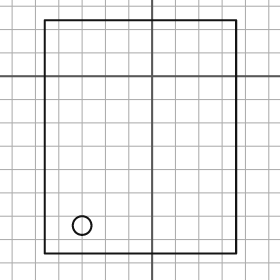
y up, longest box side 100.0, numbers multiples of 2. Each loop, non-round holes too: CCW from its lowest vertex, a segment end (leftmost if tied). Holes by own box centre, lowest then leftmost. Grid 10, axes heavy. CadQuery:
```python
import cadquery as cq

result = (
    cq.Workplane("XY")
    .moveTo(-46.0, -76.0)
    .lineTo(36.0, -76.0)
    .lineTo(36.0, 24.0)
    .lineTo(-46.0, 24.0)
    .close()
    .moveTo(-30.0, -64.0)
    .circle(4.0)
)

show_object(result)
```